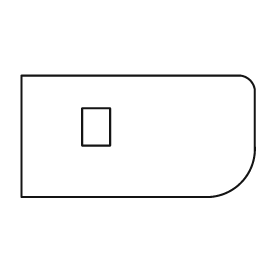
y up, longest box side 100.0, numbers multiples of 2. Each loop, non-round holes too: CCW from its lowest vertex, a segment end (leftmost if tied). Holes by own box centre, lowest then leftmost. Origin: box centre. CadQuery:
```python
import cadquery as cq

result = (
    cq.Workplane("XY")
    .moveTo(-50.0, -26.0)
    .lineTo(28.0, -26.0)
    .threePointArc((44.0, -20.0), (50.0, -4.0))
    .lineTo(50.0, 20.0)
    .threePointArc((48.0, 24.0), (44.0, 26.0))
    .lineTo(-50.0, 26.0)
    .close()
    .moveTo(-24.0, -4.0)
    .lineTo(-12.0, -4.0)
    .lineTo(-12.0, 12.0)
    .lineTo(-24.0, 12.0)
    .close()
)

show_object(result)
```